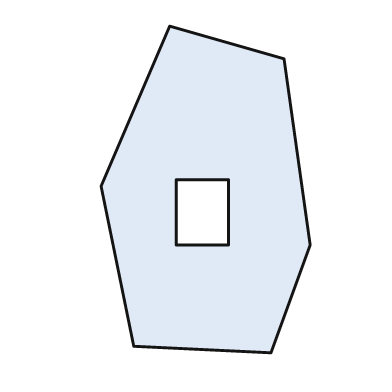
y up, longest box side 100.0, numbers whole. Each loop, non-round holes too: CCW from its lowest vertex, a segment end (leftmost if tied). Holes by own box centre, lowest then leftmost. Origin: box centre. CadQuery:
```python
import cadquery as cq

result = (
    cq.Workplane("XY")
    .moveTo(20.0, -50.0)
    .lineTo(32.0, -17.0)
    .lineTo(24.0, 40.0)
    .lineTo(-11.0, 50.0)
    .lineTo(-32.0, 1.0)
    .lineTo(-22.0, -48.0)
    .close()
    .moveTo(-9.0, -17.0)
    .lineTo(7.0, -17.0)
    .lineTo(7.0, 3.0)
    .lineTo(-9.0, 3.0)
    .close()
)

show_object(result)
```